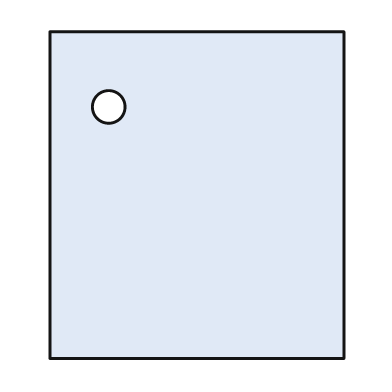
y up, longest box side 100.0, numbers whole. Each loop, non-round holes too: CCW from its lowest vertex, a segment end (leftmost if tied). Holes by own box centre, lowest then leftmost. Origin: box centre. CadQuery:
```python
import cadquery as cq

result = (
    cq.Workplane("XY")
    .moveTo(-45.0, -50.0)
    .lineTo(45.0, -50.0)
    .lineTo(45.0, 50.0)
    .lineTo(-45.0, 50.0)
    .close()
    .moveTo(-27.0, 27.0)
    .circle(5.0)
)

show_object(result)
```